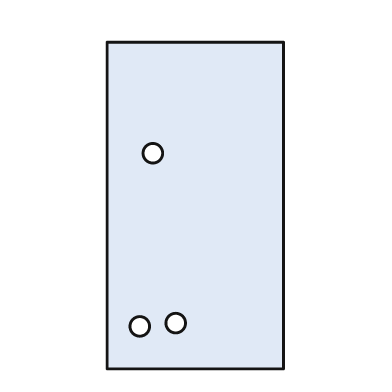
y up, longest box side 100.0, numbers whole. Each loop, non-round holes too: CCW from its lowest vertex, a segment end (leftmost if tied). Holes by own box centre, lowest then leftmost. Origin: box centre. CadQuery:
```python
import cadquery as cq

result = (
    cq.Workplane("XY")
    .moveTo(-27.0, -50.0)
    .lineTo(27.0, -50.0)
    .lineTo(27.0, 50.0)
    .lineTo(-27.0, 50.0)
    .close()
    .moveTo(-17.0, -37.0)
    .circle(3.0)
    .moveTo(-6.0, -36.0)
    .circle(3.0)
    .moveTo(-13.0, 16.0)
    .circle(3.0)
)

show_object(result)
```